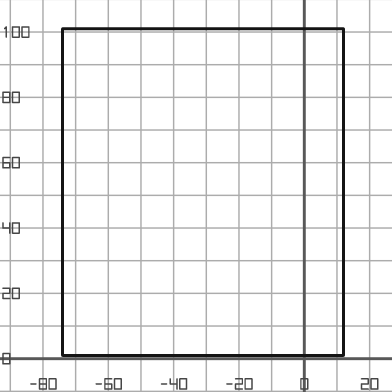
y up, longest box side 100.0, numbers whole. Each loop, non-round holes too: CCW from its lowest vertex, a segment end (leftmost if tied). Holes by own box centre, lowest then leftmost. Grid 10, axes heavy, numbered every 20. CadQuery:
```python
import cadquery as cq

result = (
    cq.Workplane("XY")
    .moveTo(-74.0, 1.0)
    .lineTo(12.0, 1.0)
    .lineTo(12.0, 101.0)
    .lineTo(-74.0, 101.0)
    .close()
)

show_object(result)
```